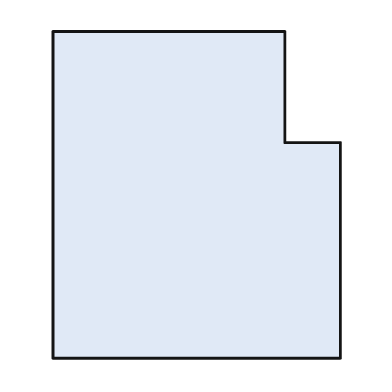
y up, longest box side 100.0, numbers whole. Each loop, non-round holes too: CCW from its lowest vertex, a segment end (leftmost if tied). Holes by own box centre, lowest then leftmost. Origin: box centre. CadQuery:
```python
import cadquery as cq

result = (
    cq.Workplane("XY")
    .moveTo(-44.0, -50.0)
    .lineTo(44.0, -50.0)
    .lineTo(44.0, 16.0)
    .lineTo(27.0, 16.0)
    .lineTo(27.0, 50.0)
    .lineTo(-44.0, 50.0)
    .close()
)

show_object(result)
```